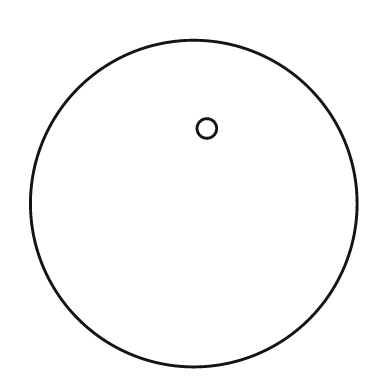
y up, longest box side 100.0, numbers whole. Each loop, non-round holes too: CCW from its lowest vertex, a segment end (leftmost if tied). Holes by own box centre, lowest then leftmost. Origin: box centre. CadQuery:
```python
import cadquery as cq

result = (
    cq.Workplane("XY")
    .moveTo(0.0, 0.0)
    .circle(50.0)
    .moveTo(4.0, 23.0)
    .circle(3.0)
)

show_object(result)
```